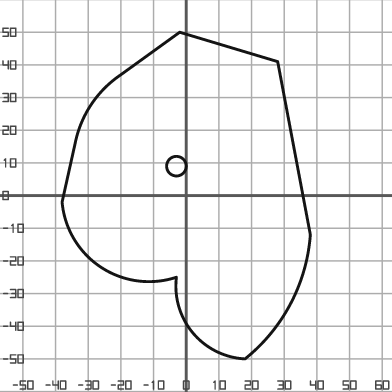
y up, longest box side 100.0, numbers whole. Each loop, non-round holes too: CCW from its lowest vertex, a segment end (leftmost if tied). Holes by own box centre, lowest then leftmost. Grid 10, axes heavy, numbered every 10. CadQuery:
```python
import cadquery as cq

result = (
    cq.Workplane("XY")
    .moveTo(18.0, -50.0)
    .threePointArc((32.0, -33.0), (38.0, -12.0))
    .lineTo(28.0, 41.0)
    .lineTo(-2.0, 50.0)
    .lineTo(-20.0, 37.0)
    .threePointArc((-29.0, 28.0), (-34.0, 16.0))
    .lineTo(-38.0, -2.0)
    .threePointArc((-26.0, -22.0), (-3.0, -25.0))
    .threePointArc((2.0, -42.0), (18.0, -50.0))
    .close()
    .moveTo(-3.0, 9.0)
    .circle(3.0)
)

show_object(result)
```